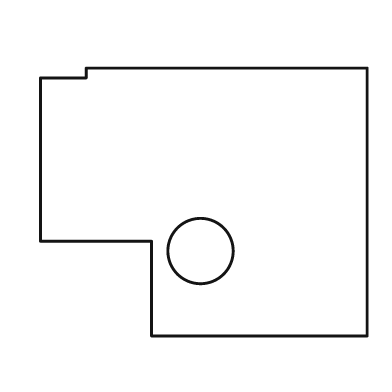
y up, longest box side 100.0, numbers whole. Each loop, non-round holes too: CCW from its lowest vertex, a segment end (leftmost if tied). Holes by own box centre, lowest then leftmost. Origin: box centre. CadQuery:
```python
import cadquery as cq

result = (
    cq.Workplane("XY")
    .moveTo(-16.0, -41.0)
    .lineTo(50.0, -41.0)
    .lineTo(50.0, 41.0)
    .lineTo(-36.0, 41.0)
    .lineTo(-36.0, 38.0)
    .lineTo(-50.0, 38.0)
    .lineTo(-50.0, -12.0)
    .lineTo(-16.0, -12.0)
    .close()
    .moveTo(-1.0, -15.0)
    .circle(10.0)
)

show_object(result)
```